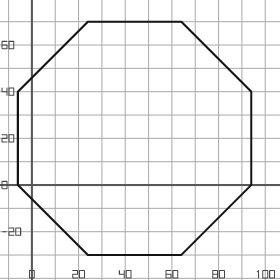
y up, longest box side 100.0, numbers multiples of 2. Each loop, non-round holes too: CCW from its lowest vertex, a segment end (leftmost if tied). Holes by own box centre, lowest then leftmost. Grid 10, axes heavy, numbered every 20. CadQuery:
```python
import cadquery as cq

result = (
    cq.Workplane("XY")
    .moveTo(24.0, -30.0)
    .lineTo(64.0, -30.0)
    .lineTo(94.0, 0.0)
    .lineTo(94.0, 40.0)
    .lineTo(64.0, 70.0)
    .lineTo(24.0, 70.0)
    .lineTo(-6.0, 40.0)
    .lineTo(-6.0, 0.0)
    .close()
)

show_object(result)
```